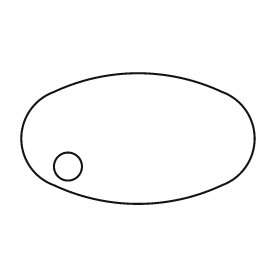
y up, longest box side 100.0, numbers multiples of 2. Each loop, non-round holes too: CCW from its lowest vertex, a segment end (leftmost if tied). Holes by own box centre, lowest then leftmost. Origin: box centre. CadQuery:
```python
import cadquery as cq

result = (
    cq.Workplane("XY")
    .moveTo(-36.0, -20.0)
    .threePointArc((0.0, -28.0), (36.0, -20.0))
    .threePointArc((50.0, 0.0), (36.0, 20.0))
    .threePointArc((0.0, 28.0), (-36.0, 20.0))
    .threePointArc((-50.0, 0.0), (-36.0, -20.0))
    .close()
    .moveTo(-30.0, -12.0)
    .circle(6.0)
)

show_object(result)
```